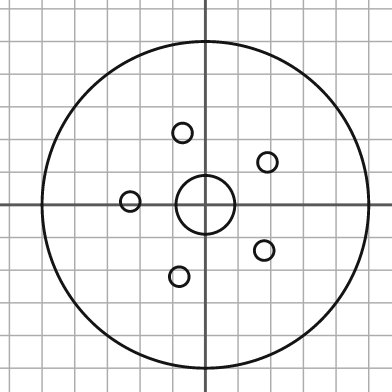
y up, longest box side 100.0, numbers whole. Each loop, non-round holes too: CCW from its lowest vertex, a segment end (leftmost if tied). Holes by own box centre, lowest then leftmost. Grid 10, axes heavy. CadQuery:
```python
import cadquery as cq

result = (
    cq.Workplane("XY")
    .moveTo(0.0, 0.0)
    .circle(50.0)
    .moveTo(-8.0, -22.0)
    .circle(3.0)
    .moveTo(18.0, -14.0)
    .circle(3.0)
    .moveTo(0.0, 0.0)
    .circle(9.0)
    .moveTo(-23.0, 1.0)
    .circle(3.0)
    .moveTo(19.0, 13.0)
    .circle(3.0)
    .moveTo(-7.0, 22.0)
    .circle(3.0)
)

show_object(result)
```